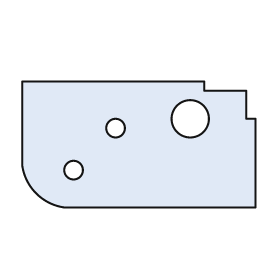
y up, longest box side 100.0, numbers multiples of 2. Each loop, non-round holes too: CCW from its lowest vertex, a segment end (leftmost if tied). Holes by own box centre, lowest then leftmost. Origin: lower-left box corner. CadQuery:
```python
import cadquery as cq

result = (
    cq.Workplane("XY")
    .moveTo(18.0, 0.0)
    .lineTo(100.0, 0.0)
    .lineTo(100.0, 38.0)
    .lineTo(96.0, 38.0)
    .lineTo(96.0, 50.0)
    .lineTo(78.0, 50.0)
    .lineTo(78.0, 54.0)
    .lineTo(0.0, 54.0)
    .lineTo(0.0, 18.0)
    .threePointArc((6.0, 6.0), (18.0, 0.0))
    .close()
    .moveTo(22.0, 16.0)
    .circle(4.0)
    .moveTo(40.0, 34.0)
    .circle(4.0)
    .moveTo(72.0, 38.0)
    .circle(8.0)
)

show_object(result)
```